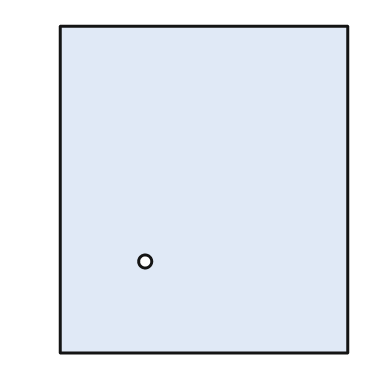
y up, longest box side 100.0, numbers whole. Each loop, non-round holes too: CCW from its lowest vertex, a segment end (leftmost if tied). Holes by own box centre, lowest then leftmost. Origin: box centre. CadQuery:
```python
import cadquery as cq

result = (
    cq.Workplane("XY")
    .moveTo(-44.0, -50.0)
    .lineTo(44.0, -50.0)
    .lineTo(44.0, 50.0)
    .lineTo(-44.0, 50.0)
    .close()
    .moveTo(-18.0, -22.0)
    .circle(2.0)
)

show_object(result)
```